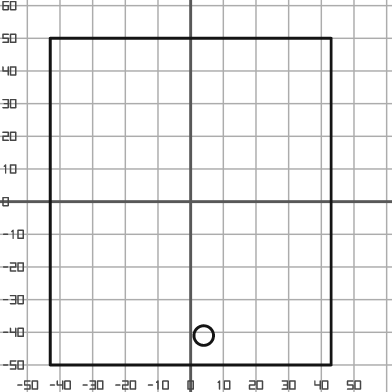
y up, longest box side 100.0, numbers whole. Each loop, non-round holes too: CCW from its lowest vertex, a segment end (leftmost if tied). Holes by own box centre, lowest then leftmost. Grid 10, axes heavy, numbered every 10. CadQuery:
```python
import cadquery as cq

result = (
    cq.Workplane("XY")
    .moveTo(-43.0, -50.0)
    .lineTo(43.0, -50.0)
    .lineTo(43.0, 50.0)
    .lineTo(-43.0, 50.0)
    .close()
    .moveTo(4.0, -41.0)
    .circle(3.0)
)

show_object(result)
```